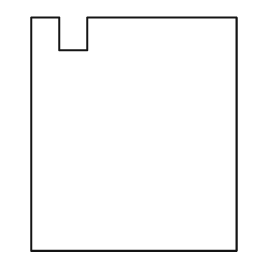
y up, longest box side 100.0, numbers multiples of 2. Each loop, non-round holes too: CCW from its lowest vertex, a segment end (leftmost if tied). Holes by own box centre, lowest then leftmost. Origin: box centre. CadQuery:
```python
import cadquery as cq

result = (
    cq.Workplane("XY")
    .moveTo(-44.0, -50.0)
    .lineTo(44.0, -50.0)
    .lineTo(44.0, 50.0)
    .lineTo(-20.0, 50.0)
    .lineTo(-20.0, 36.0)
    .lineTo(-32.0, 36.0)
    .lineTo(-32.0, 50.0)
    .lineTo(-44.0, 50.0)
    .close()
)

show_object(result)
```